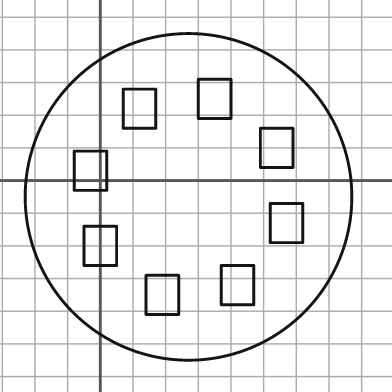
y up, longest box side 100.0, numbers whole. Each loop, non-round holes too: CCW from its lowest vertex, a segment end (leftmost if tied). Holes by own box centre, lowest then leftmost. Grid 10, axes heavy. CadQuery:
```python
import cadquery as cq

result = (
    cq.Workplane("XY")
    .moveTo(27.0, -5.0)
    .circle(50.0)
    .moveTo(14.0, -41.0)
    .lineTo(24.0, -41.0)
    .lineTo(24.0, -29.0)
    .lineTo(14.0, -29.0)
    .close()
    .moveTo(37.0, -38.0)
    .lineTo(47.0, -38.0)
    .lineTo(47.0, -26.0)
    .lineTo(37.0, -26.0)
    .close()
    .moveTo(-5.0, -26.0)
    .lineTo(5.0, -26.0)
    .lineTo(5.0, -14.0)
    .lineTo(-5.0, -14.0)
    .close()
    .moveTo(52.0, -19.0)
    .lineTo(62.0, -19.0)
    .lineTo(62.0, -7.0)
    .lineTo(52.0, -7.0)
    .close()
    .moveTo(-8.0, -3.0)
    .lineTo(2.0, -3.0)
    .lineTo(2.0, 9.0)
    .lineTo(-8.0, 9.0)
    .close()
    .moveTo(49.0, 4.0)
    .lineTo(59.0, 4.0)
    .lineTo(59.0, 16.0)
    .lineTo(49.0, 16.0)
    .close()
    .moveTo(7.0, 16.0)
    .lineTo(17.0, 16.0)
    .lineTo(17.0, 28.0)
    .lineTo(7.0, 28.0)
    .close()
    .moveTo(30.0, 19.0)
    .lineTo(40.0, 19.0)
    .lineTo(40.0, 31.0)
    .lineTo(30.0, 31.0)
    .close()
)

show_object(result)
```